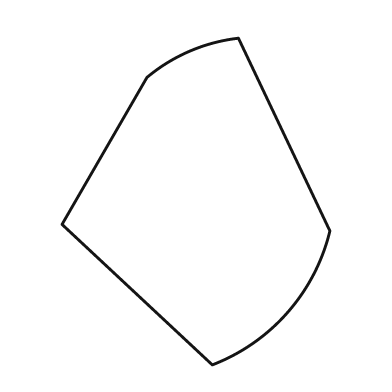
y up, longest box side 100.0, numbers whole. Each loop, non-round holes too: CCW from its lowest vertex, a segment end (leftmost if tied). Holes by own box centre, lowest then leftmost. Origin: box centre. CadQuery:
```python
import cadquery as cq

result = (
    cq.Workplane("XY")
    .moveTo(5.0, -50.0)
    .threePointArc((28.0, -34.0), (41.0, -9.0))
    .lineTo(13.0, 50.0)
    .threePointArc((-2.0, 46.0), (-15.0, 38.0))
    .lineTo(-41.0, -7.0)
    .close()
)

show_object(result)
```